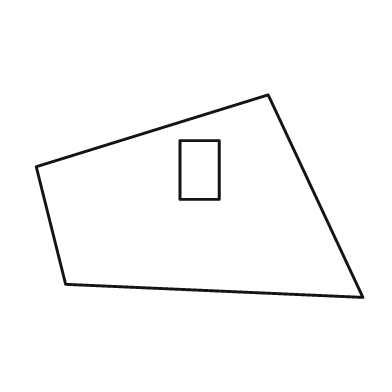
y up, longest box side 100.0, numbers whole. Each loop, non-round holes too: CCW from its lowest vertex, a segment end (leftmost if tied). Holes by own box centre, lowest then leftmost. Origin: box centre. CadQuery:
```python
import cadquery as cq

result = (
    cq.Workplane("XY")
    .moveTo(50.0, -31.0)
    .lineTo(21.0, 31.0)
    .lineTo(-50.0, 9.0)
    .lineTo(-41.0, -27.0)
    .close()
    .moveTo(-6.0, -1.0)
    .lineTo(6.0, -1.0)
    .lineTo(6.0, 17.0)
    .lineTo(-6.0, 17.0)
    .close()
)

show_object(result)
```